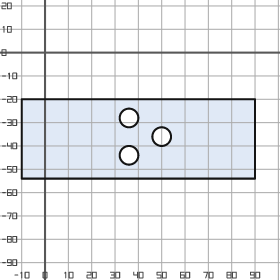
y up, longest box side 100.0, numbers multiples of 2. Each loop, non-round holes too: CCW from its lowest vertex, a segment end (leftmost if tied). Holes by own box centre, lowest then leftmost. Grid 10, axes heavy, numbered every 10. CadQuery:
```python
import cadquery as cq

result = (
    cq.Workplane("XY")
    .moveTo(-10.0, -54.0)
    .lineTo(90.0, -54.0)
    .lineTo(90.0, -20.0)
    .lineTo(-10.0, -20.0)
    .close()
    .moveTo(36.0, -44.0)
    .circle(4.0)
    .moveTo(50.0, -36.0)
    .circle(4.0)
    .moveTo(36.0, -28.0)
    .circle(4.0)
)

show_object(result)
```